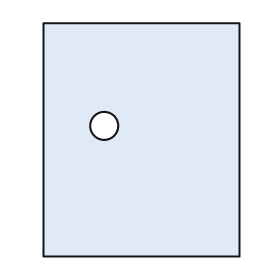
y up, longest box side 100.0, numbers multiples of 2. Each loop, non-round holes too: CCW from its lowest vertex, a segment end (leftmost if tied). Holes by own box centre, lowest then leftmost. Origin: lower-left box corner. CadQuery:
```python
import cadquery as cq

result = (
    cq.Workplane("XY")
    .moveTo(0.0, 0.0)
    .lineTo(84.0, 0.0)
    .lineTo(84.0, 100.0)
    .lineTo(0.0, 100.0)
    .close()
    .moveTo(26.0, 56.0)
    .circle(6.0)
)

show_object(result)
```